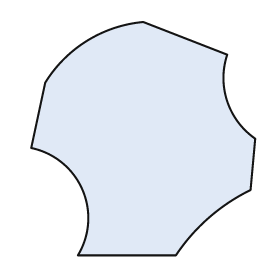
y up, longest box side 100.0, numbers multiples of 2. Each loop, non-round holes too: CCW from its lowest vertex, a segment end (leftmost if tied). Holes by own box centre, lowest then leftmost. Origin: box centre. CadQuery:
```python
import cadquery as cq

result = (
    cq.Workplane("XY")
    .moveTo(-28.0, -50.0)
    .lineTo(14.0, -50.0)
    .threePointArc((28.0, -34.0), (46.0, -22.0))
    .lineTo(48.0, 0.0)
    .threePointArc((36.0, 16.0), (36.0, 36.0))
    .lineTo(0.0, 50.0)
    .threePointArc((-24.0, 42.0), (-42.0, 24.0))
    .lineTo(-48.0, -4.0)
    .threePointArc((-26.0, -22.0), (-28.0, -50.0))
    .close()
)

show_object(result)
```